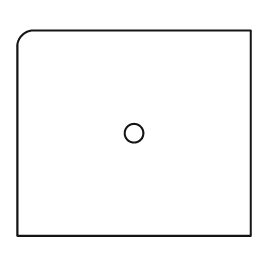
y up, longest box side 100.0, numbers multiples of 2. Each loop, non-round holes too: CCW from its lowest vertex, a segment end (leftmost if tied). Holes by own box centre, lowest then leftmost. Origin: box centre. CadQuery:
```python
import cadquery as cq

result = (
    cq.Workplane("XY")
    .moveTo(-50.0, -44.0)
    .lineTo(50.0, -44.0)
    .lineTo(50.0, 44.0)
    .lineTo(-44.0, 44.0)
    .threePointArc((-48.0, 42.0), (-50.0, 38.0))
    .close()
    .moveTo(0.0, 0.0)
    .circle(4.0)
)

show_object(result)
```